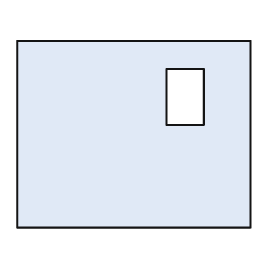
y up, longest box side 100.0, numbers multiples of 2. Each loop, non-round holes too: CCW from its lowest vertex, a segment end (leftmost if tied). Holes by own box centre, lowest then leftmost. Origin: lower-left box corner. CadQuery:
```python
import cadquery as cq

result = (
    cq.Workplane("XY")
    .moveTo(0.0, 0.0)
    .lineTo(100.0, 0.0)
    .lineTo(100.0, 80.0)
    .lineTo(0.0, 80.0)
    .close()
    .moveTo(64.0, 44.0)
    .lineTo(80.0, 44.0)
    .lineTo(80.0, 68.0)
    .lineTo(64.0, 68.0)
    .close()
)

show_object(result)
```